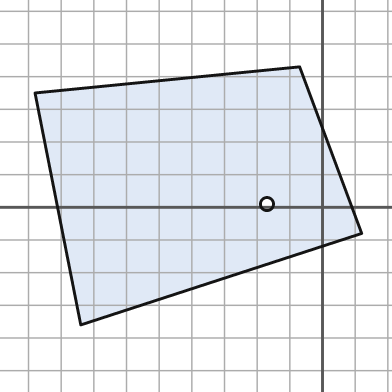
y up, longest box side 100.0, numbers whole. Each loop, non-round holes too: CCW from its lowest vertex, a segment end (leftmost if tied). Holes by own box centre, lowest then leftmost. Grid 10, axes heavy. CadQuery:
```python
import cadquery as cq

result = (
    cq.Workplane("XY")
    .moveTo(-74.0, -36.0)
    .lineTo(12.0, -8.0)
    .lineTo(-7.0, 43.0)
    .lineTo(-88.0, 35.0)
    .close()
    .moveTo(-17.0, 1.0)
    .circle(2.0)
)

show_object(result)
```